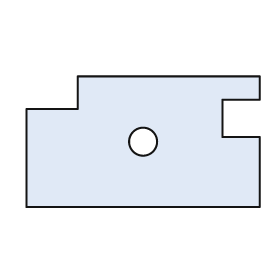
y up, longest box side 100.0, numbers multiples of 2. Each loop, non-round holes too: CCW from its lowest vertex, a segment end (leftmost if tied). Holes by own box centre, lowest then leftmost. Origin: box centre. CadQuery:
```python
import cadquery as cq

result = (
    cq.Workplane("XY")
    .moveTo(-50.0, -28.0)
    .lineTo(50.0, -28.0)
    .lineTo(50.0, 2.0)
    .lineTo(34.0, 2.0)
    .lineTo(34.0, 18.0)
    .lineTo(50.0, 18.0)
    .lineTo(50.0, 28.0)
    .lineTo(-28.0, 28.0)
    .lineTo(-28.0, 14.0)
    .lineTo(-50.0, 14.0)
    .close()
    .moveTo(0.0, 0.0)
    .circle(6.0)
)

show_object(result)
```